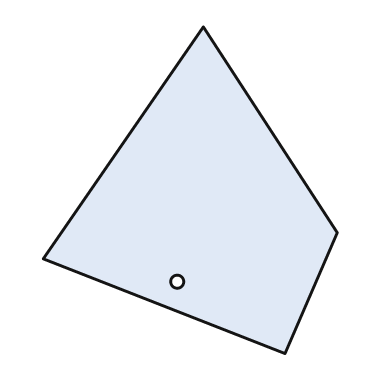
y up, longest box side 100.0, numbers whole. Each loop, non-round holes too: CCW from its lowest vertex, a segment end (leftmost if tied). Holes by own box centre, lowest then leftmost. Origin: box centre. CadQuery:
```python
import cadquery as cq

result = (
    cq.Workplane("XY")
    .moveTo(29.0, -50.0)
    .lineTo(45.0, -13.0)
    .lineTo(4.0, 50.0)
    .lineTo(-45.0, -21.0)
    .close()
    .moveTo(-4.0, -28.0)
    .circle(2.0)
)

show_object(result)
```